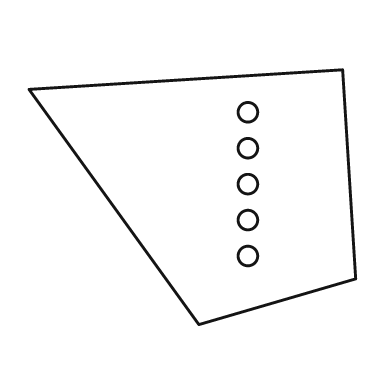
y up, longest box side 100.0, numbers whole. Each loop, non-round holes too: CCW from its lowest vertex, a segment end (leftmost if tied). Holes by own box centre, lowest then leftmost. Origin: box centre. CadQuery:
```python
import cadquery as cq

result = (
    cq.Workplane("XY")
    .moveTo(2.0, -39.0)
    .lineTo(50.0, -25.0)
    .lineTo(46.0, 39.0)
    .lineTo(-50.0, 33.0)
    .close()
    .moveTo(17.0, -18.0)
    .circle(3.0)
    .moveTo(17.0, -7.0)
    .circle(3.0)
    .moveTo(17.0, 4.0)
    .circle(3.0)
    .moveTo(17.0, 15.0)
    .circle(3.0)
    .moveTo(17.0, 26.0)
    .circle(3.0)
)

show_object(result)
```